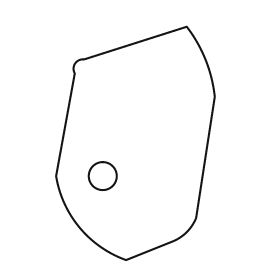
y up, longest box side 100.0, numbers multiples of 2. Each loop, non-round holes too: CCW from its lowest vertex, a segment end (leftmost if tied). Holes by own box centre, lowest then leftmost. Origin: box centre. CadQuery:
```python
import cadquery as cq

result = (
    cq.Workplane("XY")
    .moveTo(-4.0, -50.0)
    .lineTo(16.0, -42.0)
    .threePointArc((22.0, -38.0), (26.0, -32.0))
    .lineTo(34.0, 20.0)
    .threePointArc((30.0, 36.0), (22.0, 50.0))
    .lineTo(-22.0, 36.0)
    .threePointArc((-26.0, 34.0), (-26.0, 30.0))
    .lineTo(-34.0, -14.0)
    .threePointArc((-24.0, -36.0), (-4.0, -50.0))
    .close()
    .moveTo(-14.0, -14.0)
    .circle(6.0)
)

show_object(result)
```